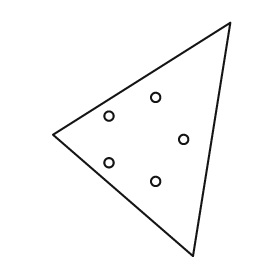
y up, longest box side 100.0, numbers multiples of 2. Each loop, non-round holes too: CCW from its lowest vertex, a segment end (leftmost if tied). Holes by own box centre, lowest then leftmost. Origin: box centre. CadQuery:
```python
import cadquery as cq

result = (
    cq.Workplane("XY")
    .moveTo(22.0, -50.0)
    .lineTo(38.0, 50.0)
    .lineTo(-38.0, 2.0)
    .close()
    .moveTo(6.0, -18.0)
    .circle(2.0)
    .moveTo(-14.0, -10.0)
    .circle(2.0)
    .moveTo(18.0, 0.0)
    .circle(2.0)
    .moveTo(-14.0, 10.0)
    .circle(2.0)
    .moveTo(6.0, 18.0)
    .circle(2.0)
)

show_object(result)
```